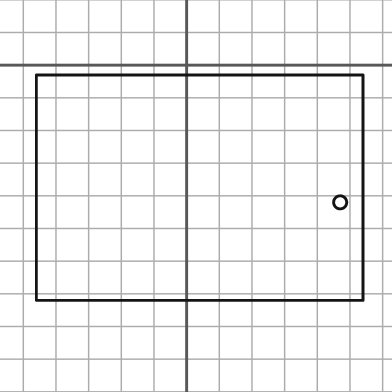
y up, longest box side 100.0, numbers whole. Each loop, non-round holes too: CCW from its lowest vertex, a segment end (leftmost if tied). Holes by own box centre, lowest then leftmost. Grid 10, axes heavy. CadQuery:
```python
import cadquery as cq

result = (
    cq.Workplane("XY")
    .moveTo(-46.0, -72.0)
    .lineTo(54.0, -72.0)
    .lineTo(54.0, -3.0)
    .lineTo(-46.0, -3.0)
    .close()
    .moveTo(47.0, -42.0)
    .circle(2.0)
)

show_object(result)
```